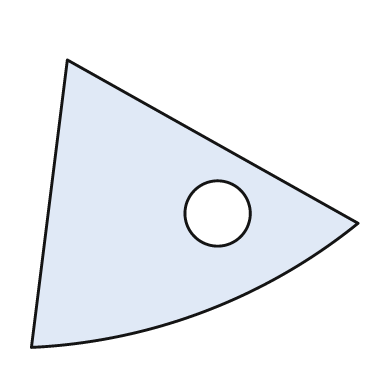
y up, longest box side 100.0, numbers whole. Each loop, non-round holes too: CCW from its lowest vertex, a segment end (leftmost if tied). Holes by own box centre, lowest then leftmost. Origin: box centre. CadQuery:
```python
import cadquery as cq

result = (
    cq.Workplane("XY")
    .moveTo(-50.0, -44.0)
    .threePointArc((3.0, -33.0), (50.0, -6.0))
    .lineTo(-39.0, 44.0)
    .close()
    .moveTo(7.0, -3.0)
    .circle(10.0)
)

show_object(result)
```